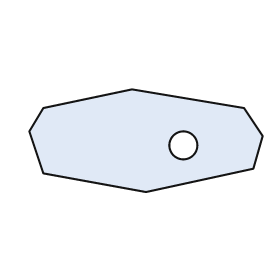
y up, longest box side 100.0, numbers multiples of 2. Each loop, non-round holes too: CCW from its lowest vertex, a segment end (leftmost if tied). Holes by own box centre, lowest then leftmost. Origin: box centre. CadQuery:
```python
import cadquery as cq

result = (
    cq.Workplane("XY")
    .moveTo(0.0, -22.0)
    .lineTo(46.0, -12.0)
    .lineTo(50.0, 2.0)
    .lineTo(42.0, 14.0)
    .lineTo(-6.0, 22.0)
    .lineTo(-44.0, 14.0)
    .lineTo(-50.0, 4.0)
    .lineTo(-44.0, -14.0)
    .close()
    .moveTo(16.0, -2.0)
    .circle(6.0)
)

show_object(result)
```